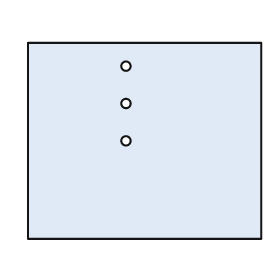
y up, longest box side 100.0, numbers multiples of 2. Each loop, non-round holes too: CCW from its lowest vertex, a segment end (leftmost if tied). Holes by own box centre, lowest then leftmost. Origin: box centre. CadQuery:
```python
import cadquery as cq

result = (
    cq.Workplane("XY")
    .moveTo(-50.0, -42.0)
    .lineTo(50.0, -42.0)
    .lineTo(50.0, 42.0)
    .lineTo(-50.0, 42.0)
    .close()
    .moveTo(-8.0, 0.0)
    .circle(2.0)
    .moveTo(-8.0, 16.0)
    .circle(2.0)
    .moveTo(-8.0, 32.0)
    .circle(2.0)
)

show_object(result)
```